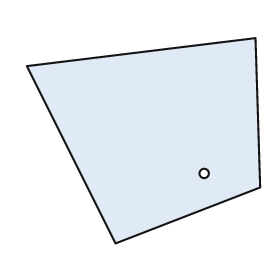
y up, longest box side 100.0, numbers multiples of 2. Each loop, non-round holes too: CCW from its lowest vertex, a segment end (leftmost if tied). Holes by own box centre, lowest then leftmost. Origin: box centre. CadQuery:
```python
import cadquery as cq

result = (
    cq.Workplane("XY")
    .moveTo(-12.0, -44.0)
    .lineTo(50.0, -20.0)
    .lineTo(48.0, 44.0)
    .lineTo(-50.0, 32.0)
    .close()
    .moveTo(26.0, -14.0)
    .circle(2.0)
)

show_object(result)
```